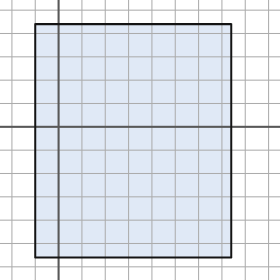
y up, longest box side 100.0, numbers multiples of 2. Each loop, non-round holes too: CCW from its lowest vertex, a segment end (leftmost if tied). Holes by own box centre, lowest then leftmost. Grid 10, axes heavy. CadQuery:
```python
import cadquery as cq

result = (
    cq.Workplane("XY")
    .moveTo(-10.0, -56.0)
    .lineTo(74.0, -56.0)
    .lineTo(74.0, 44.0)
    .lineTo(-10.0, 44.0)
    .close()
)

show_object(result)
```